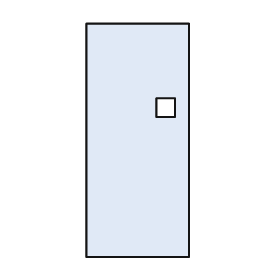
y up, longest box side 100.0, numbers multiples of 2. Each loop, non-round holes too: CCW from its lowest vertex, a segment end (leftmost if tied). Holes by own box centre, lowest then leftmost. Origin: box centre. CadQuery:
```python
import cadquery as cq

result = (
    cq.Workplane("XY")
    .moveTo(-22.0, -50.0)
    .lineTo(22.0, -50.0)
    .lineTo(22.0, 50.0)
    .lineTo(-22.0, 50.0)
    .close()
    .moveTo(8.0, 10.0)
    .lineTo(16.0, 10.0)
    .lineTo(16.0, 18.0)
    .lineTo(8.0, 18.0)
    .close()
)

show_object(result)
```